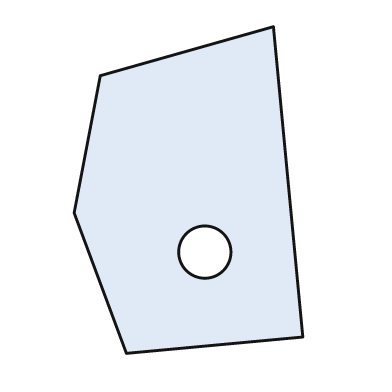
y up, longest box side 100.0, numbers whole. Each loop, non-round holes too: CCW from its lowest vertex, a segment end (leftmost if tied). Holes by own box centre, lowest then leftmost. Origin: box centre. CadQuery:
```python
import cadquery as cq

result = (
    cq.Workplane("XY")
    .moveTo(-19.0, -50.0)
    .lineTo(35.0, -45.0)
    .lineTo(26.0, 50.0)
    .lineTo(-27.0, 35.0)
    .lineTo(-35.0, -7.0)
    .close()
    .moveTo(5.0, -19.0)
    .circle(8.0)
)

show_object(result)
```